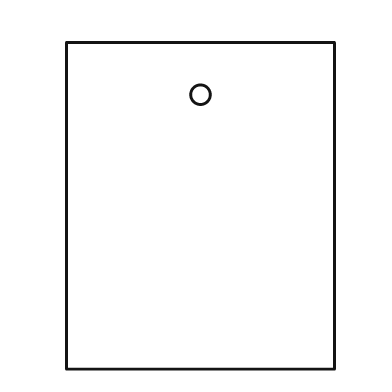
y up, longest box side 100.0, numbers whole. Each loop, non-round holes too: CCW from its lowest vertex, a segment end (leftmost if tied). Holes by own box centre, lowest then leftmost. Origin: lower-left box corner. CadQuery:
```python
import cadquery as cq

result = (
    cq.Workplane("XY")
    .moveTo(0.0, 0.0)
    .lineTo(82.0, 0.0)
    .lineTo(82.0, 100.0)
    .lineTo(0.0, 100.0)
    .close()
    .moveTo(41.0, 84.0)
    .circle(3.0)
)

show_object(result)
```